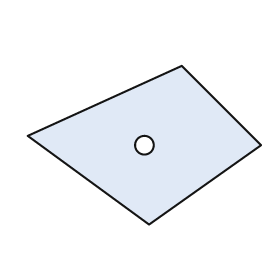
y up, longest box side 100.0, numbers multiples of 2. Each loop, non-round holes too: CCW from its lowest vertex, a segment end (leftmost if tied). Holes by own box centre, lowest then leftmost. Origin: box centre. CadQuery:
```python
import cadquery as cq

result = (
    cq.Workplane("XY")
    .moveTo(2.0, -34.0)
    .lineTo(50.0, 0.0)
    .lineTo(16.0, 34.0)
    .lineTo(-50.0, 4.0)
    .close()
    .moveTo(0.0, 0.0)
    .circle(4.0)
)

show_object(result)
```